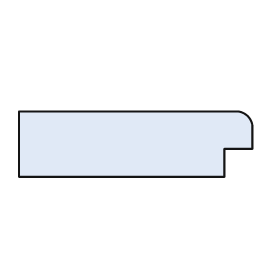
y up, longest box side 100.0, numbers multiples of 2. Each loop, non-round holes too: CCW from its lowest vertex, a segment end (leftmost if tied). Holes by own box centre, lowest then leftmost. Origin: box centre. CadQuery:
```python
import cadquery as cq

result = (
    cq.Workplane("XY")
    .moveTo(-50.0, -14.0)
    .lineTo(38.0, -14.0)
    .lineTo(38.0, -2.0)
    .lineTo(50.0, -2.0)
    .lineTo(50.0, 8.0)
    .threePointArc((48.0, 12.0), (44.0, 14.0))
    .lineTo(-50.0, 14.0)
    .close()
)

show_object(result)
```